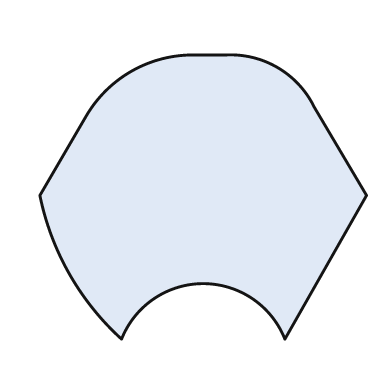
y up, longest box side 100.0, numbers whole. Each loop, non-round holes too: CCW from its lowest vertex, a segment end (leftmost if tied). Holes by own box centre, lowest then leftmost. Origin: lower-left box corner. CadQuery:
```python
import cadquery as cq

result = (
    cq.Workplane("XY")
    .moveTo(25.0, 0.0)
    .threePointArc((50.0, 17.0), (75.0, 0.0))
    .lineTo(100.0, 44.0)
    .lineTo(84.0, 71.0)
    .threePointArc((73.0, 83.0), (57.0, 87.0))
    .lineTo(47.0, 87.0)
    .threePointArc((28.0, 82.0), (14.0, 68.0))
    .lineTo(0.0, 44.0)
    .threePointArc((9.0, 20.0), (25.0, 0.0))
    .close()
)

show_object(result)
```